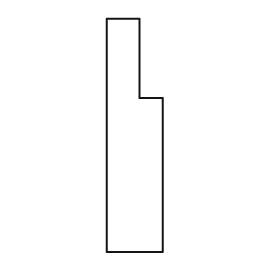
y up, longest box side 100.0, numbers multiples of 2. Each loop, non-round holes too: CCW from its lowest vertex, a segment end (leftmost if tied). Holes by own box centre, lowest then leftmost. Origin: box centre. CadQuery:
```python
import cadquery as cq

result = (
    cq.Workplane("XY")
    .moveTo(-12.0, -50.0)
    .lineTo(12.0, -50.0)
    .lineTo(12.0, 16.0)
    .lineTo(2.0, 16.0)
    .lineTo(2.0, 50.0)
    .lineTo(-12.0, 50.0)
    .close()
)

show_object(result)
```